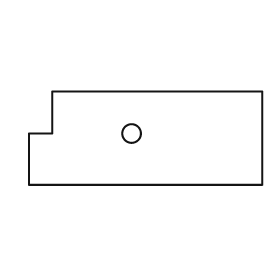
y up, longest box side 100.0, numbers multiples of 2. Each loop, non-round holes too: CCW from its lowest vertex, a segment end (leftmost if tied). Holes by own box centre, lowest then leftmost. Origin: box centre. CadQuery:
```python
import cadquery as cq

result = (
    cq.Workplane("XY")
    .moveTo(-50.0, -20.0)
    .lineTo(50.0, -20.0)
    .lineTo(50.0, 20.0)
    .lineTo(-40.0, 20.0)
    .lineTo(-40.0, 2.0)
    .lineTo(-50.0, 2.0)
    .close()
    .moveTo(-6.0, 2.0)
    .circle(4.0)
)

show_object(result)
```